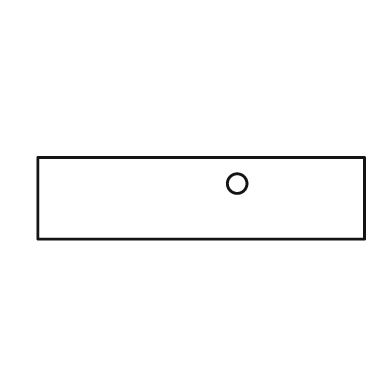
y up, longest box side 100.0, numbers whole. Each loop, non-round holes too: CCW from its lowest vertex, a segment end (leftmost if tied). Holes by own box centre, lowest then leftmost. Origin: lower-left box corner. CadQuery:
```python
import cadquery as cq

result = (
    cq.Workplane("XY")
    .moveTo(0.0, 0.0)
    .lineTo(100.0, 0.0)
    .lineTo(100.0, 25.0)
    .lineTo(0.0, 25.0)
    .close()
    .moveTo(61.0, 17.0)
    .circle(3.0)
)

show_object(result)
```